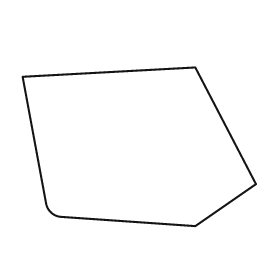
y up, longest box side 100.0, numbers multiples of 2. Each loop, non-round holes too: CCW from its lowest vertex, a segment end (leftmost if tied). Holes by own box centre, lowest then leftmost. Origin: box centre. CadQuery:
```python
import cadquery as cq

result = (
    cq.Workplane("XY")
    .moveTo(24.0, -34.0)
    .lineTo(50.0, -16.0)
    .lineTo(24.0, 34.0)
    .lineTo(-50.0, 30.0)
    .lineTo(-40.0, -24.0)
    .threePointArc((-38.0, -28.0), (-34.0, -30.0))
    .close()
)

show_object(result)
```